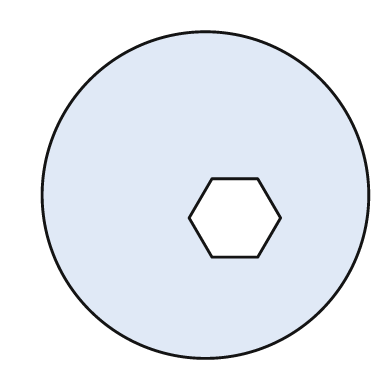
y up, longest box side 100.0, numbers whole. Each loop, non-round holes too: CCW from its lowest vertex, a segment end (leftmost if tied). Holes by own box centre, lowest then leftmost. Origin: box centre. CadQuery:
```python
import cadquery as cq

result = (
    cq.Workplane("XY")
    .moveTo(0.0, 0.0)
    .circle(50.0)
    .moveTo(2.0, -19.0)
    .lineTo(16.0, -19.0)
    .lineTo(23.0, -7.0)
    .lineTo(16.0, 5.0)
    .lineTo(2.0, 5.0)
    .lineTo(-5.0, -7.0)
    .close()
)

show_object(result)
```